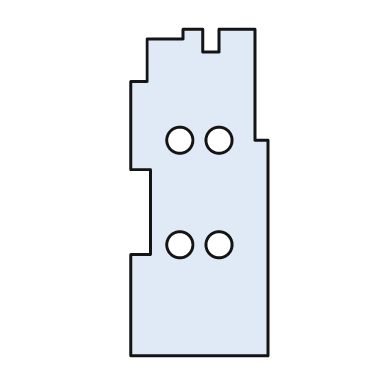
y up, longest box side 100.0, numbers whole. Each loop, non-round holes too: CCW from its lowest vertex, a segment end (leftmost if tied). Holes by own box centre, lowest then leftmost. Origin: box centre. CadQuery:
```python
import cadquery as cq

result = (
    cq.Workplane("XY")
    .moveTo(-21.0, -50.0)
    .lineTo(21.0, -50.0)
    .lineTo(21.0, 16.0)
    .lineTo(17.0, 16.0)
    .lineTo(17.0, 50.0)
    .lineTo(6.0, 50.0)
    .lineTo(6.0, 43.0)
    .lineTo(1.0, 43.0)
    .lineTo(1.0, 50.0)
    .lineTo(-5.0, 50.0)
    .lineTo(-5.0, 47.0)
    .lineTo(-16.0, 47.0)
    .lineTo(-16.0, 34.0)
    .lineTo(-21.0, 34.0)
    .lineTo(-21.0, 7.0)
    .lineTo(-15.0, 7.0)
    .lineTo(-15.0, -19.0)
    .lineTo(-21.0, -19.0)
    .close()
    .moveTo(-6.0, -16.0)
    .circle(4.0)
    .moveTo(6.0, -16.0)
    .circle(4.0)
    .moveTo(-6.0, 16.0)
    .circle(4.0)
    .moveTo(6.0, 16.0)
    .circle(4.0)
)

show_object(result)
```